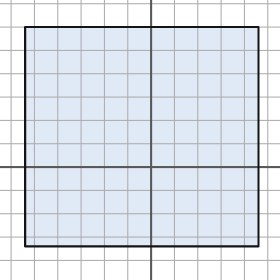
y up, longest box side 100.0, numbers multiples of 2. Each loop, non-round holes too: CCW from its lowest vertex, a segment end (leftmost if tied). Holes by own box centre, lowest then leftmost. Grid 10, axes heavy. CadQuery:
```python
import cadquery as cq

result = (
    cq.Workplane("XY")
    .moveTo(-54.0, -34.0)
    .lineTo(46.0, -34.0)
    .lineTo(46.0, 60.0)
    .lineTo(-54.0, 60.0)
    .close()
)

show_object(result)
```